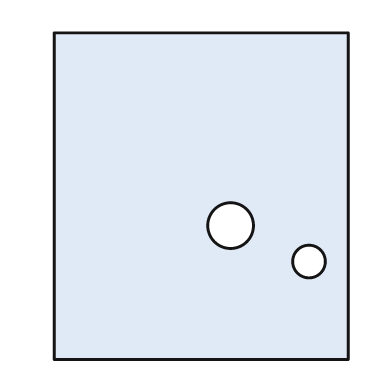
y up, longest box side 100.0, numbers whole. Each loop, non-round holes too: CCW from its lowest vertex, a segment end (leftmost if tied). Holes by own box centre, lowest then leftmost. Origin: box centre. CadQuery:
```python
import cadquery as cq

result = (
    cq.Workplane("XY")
    .moveTo(-45.0, -50.0)
    .lineTo(45.0, -50.0)
    .lineTo(45.0, 50.0)
    .lineTo(-45.0, 50.0)
    .close()
    .moveTo(33.0, -20.0)
    .circle(5.0)
    .moveTo(9.0, -9.0)
    .circle(7.0)
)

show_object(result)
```